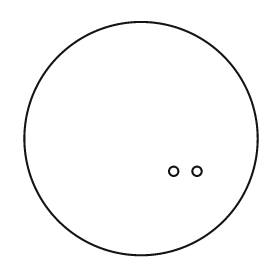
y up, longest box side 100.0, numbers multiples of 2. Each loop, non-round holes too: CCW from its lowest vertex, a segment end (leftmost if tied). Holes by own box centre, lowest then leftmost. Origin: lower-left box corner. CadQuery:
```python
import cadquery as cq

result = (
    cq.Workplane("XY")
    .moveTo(50.0, 50.0)
    .circle(50.0)
    .moveTo(64.0, 36.0)
    .circle(2.0)
    .moveTo(74.0, 36.0)
    .circle(2.0)
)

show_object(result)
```